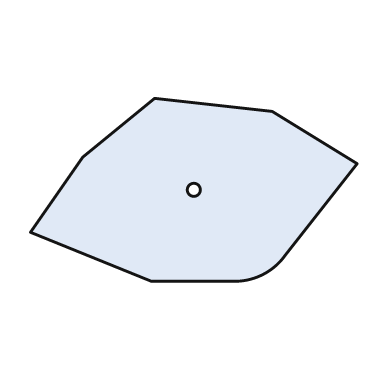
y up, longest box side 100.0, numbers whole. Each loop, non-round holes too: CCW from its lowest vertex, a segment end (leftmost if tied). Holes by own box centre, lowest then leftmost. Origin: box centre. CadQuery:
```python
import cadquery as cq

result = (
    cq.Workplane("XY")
    .moveTo(-13.0, -28.0)
    .lineTo(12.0, -28.0)
    .threePointArc((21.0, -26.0), (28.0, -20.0))
    .lineTo(50.0, 8.0)
    .lineTo(24.0, 24.0)
    .lineTo(-12.0, 28.0)
    .lineTo(-34.0, 10.0)
    .lineTo(-50.0, -13.0)
    .close()
    .moveTo(0.0, 0.0)
    .circle(2.0)
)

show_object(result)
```